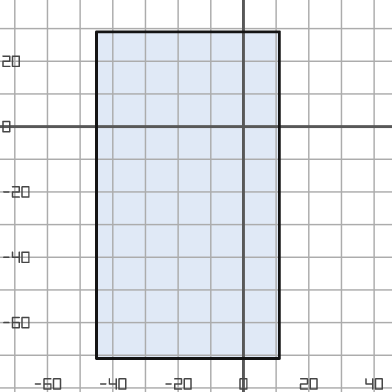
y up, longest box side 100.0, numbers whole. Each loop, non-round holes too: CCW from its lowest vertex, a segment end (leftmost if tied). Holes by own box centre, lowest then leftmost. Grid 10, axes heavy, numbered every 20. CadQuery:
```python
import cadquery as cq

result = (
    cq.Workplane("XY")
    .moveTo(-45.0, -71.0)
    .lineTo(11.0, -71.0)
    .lineTo(11.0, 29.0)
    .lineTo(-45.0, 29.0)
    .close()
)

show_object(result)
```